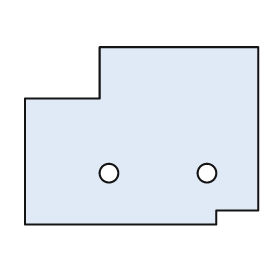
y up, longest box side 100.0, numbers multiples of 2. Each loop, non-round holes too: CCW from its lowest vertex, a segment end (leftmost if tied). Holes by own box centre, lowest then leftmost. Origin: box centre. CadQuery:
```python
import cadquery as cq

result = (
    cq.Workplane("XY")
    .moveTo(-50.0, -38.0)
    .lineTo(32.0, -38.0)
    .lineTo(32.0, -32.0)
    .lineTo(50.0, -32.0)
    .lineTo(50.0, 38.0)
    .lineTo(-18.0, 38.0)
    .lineTo(-18.0, 16.0)
    .lineTo(-50.0, 16.0)
    .close()
    .moveTo(-14.0, -16.0)
    .circle(4.0)
    .moveTo(28.0, -16.0)
    .circle(4.0)
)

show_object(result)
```